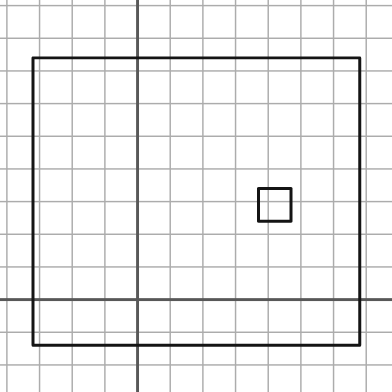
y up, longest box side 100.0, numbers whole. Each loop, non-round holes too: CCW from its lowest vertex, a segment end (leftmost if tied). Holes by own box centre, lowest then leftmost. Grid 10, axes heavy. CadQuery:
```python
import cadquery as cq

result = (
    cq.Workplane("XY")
    .moveTo(-32.0, -14.0)
    .lineTo(68.0, -14.0)
    .lineTo(68.0, 74.0)
    .lineTo(-32.0, 74.0)
    .close()
    .moveTo(37.0, 24.0)
    .lineTo(47.0, 24.0)
    .lineTo(47.0, 34.0)
    .lineTo(37.0, 34.0)
    .close()
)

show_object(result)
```